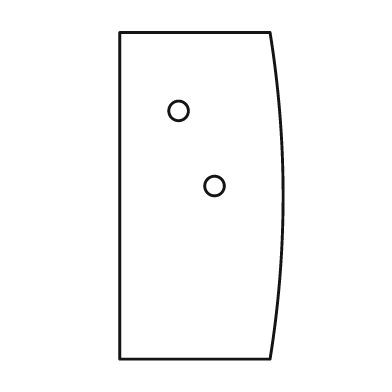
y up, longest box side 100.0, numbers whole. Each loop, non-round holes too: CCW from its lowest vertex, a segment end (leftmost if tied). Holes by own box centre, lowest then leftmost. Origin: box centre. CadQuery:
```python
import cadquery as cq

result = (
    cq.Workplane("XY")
    .moveTo(-25.0, -50.0)
    .lineTo(21.0, -50.0)
    .threePointArc((25.0, 0.0), (21.0, 50.0))
    .lineTo(-25.0, 50.0)
    .close()
    .moveTo(4.0, 3.0)
    .circle(3.0)
    .moveTo(-7.0, 26.0)
    .circle(3.0)
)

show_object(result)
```